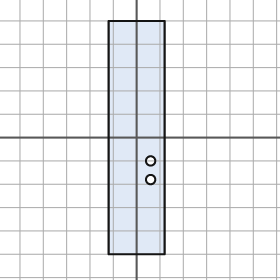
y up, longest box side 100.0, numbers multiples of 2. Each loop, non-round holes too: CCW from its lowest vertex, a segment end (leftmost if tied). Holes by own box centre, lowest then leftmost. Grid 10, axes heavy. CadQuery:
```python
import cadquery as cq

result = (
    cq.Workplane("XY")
    .moveTo(-12.0, -50.0)
    .lineTo(12.0, -50.0)
    .lineTo(12.0, 50.0)
    .lineTo(-12.0, 50.0)
    .close()
    .moveTo(6.0, -18.0)
    .circle(2.0)
    .moveTo(6.0, -10.0)
    .circle(2.0)
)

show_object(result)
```